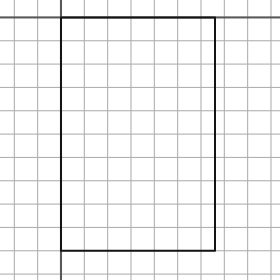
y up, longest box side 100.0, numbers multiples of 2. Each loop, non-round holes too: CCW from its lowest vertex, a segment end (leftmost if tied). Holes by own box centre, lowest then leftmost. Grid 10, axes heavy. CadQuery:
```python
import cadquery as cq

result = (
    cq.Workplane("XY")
    .moveTo(0.0, -100.0)
    .lineTo(66.0, -100.0)
    .lineTo(66.0, 0.0)
    .lineTo(0.0, 0.0)
    .close()
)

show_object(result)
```